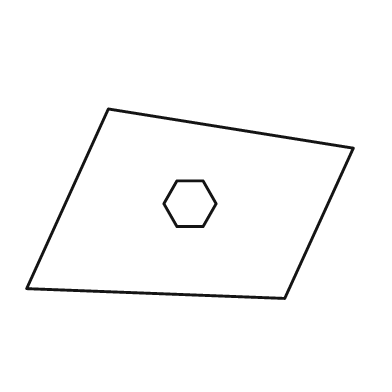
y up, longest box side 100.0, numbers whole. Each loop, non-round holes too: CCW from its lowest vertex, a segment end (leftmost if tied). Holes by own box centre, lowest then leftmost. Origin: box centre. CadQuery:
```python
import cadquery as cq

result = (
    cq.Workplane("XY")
    .moveTo(29.0, -29.0)
    .lineTo(50.0, 17.0)
    .lineTo(-25.0, 29.0)
    .lineTo(-50.0, -26.0)
    .close()
    .moveTo(-4.0, -7.0)
    .lineTo(4.0, -7.0)
    .lineTo(8.0, 0.0)
    .lineTo(4.0, 7.0)
    .lineTo(-4.0, 7.0)
    .lineTo(-8.0, 0.0)
    .close()
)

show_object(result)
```